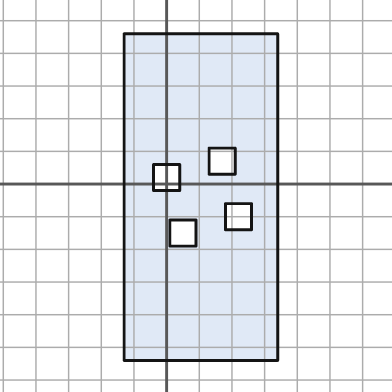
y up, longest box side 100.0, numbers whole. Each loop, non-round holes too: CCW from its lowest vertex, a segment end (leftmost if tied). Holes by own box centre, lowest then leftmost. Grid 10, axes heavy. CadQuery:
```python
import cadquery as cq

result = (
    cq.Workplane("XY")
    .moveTo(-13.0, -54.0)
    .lineTo(34.0, -54.0)
    .lineTo(34.0, 46.0)
    .lineTo(-13.0, 46.0)
    .close()
    .moveTo(1.0, -19.0)
    .lineTo(9.0, -19.0)
    .lineTo(9.0, -11.0)
    .lineTo(1.0, -11.0)
    .close()
    .moveTo(18.0, -14.0)
    .lineTo(26.0, -14.0)
    .lineTo(26.0, -6.0)
    .lineTo(18.0, -6.0)
    .close()
    .moveTo(-4.0, -2.0)
    .lineTo(4.0, -2.0)
    .lineTo(4.0, 6.0)
    .lineTo(-4.0, 6.0)
    .close()
    .moveTo(13.0, 3.0)
    .lineTo(21.0, 3.0)
    .lineTo(21.0, 11.0)
    .lineTo(13.0, 11.0)
    .close()
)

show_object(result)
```